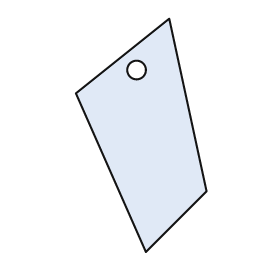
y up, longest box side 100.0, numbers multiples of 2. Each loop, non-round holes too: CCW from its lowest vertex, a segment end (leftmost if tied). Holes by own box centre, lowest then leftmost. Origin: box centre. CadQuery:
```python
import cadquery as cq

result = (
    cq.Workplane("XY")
    .moveTo(2.0, -50.0)
    .lineTo(28.0, -24.0)
    .lineTo(12.0, 50.0)
    .lineTo(-28.0, 18.0)
    .close()
    .moveTo(-2.0, 28.0)
    .circle(4.0)
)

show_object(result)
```